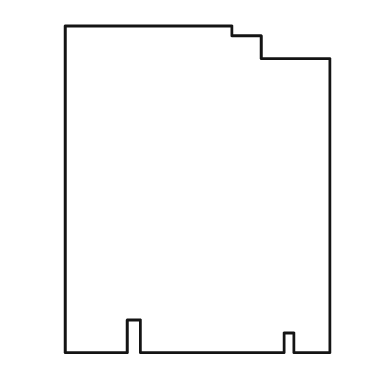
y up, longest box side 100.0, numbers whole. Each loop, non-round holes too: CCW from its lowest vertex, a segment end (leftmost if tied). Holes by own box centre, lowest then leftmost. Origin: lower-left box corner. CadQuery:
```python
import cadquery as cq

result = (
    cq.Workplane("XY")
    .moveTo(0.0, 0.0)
    .lineTo(19.0, 0.0)
    .lineTo(19.0, 10.0)
    .lineTo(23.0, 10.0)
    .lineTo(23.0, 0.0)
    .lineTo(67.0, 0.0)
    .lineTo(67.0, 6.0)
    .lineTo(70.0, 6.0)
    .lineTo(70.0, 0.0)
    .lineTo(81.0, 0.0)
    .lineTo(81.0, 90.0)
    .lineTo(60.0, 90.0)
    .lineTo(60.0, 97.0)
    .lineTo(51.0, 97.0)
    .lineTo(51.0, 100.0)
    .lineTo(0.0, 100.0)
    .close()
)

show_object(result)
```